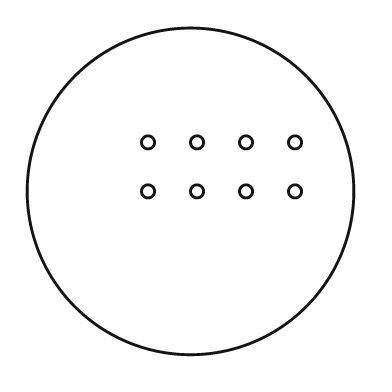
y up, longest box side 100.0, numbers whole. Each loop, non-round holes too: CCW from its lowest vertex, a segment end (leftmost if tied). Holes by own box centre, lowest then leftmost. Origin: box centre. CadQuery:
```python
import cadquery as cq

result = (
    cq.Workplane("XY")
    .moveTo(0.0, 0.0)
    .circle(50.0)
    .moveTo(-13.0, 0.0)
    .circle(2.0)
    .moveTo(2.0, 0.0)
    .circle(2.0)
    .moveTo(17.0, 0.0)
    .circle(2.0)
    .moveTo(32.0, 0.0)
    .circle(2.0)
    .moveTo(-13.0, 15.0)
    .circle(2.0)
    .moveTo(2.0, 15.0)
    .circle(2.0)
    .moveTo(17.0, 15.0)
    .circle(2.0)
    .moveTo(32.0, 15.0)
    .circle(2.0)
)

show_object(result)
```